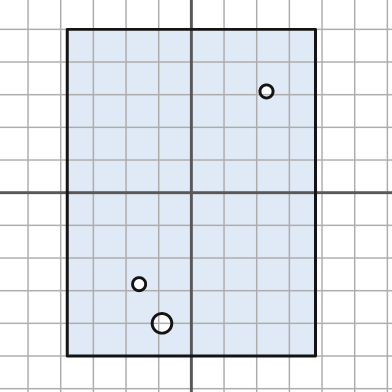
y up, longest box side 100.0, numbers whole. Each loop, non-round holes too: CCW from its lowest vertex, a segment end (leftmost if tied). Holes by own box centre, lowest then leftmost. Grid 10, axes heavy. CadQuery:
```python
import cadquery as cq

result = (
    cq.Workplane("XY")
    .moveTo(-38.0, -50.0)
    .lineTo(38.0, -50.0)
    .lineTo(38.0, 50.0)
    .lineTo(-38.0, 50.0)
    .close()
    .moveTo(-9.0, -40.0)
    .circle(3.0)
    .moveTo(-16.0, -28.0)
    .circle(2.0)
    .moveTo(23.0, 31.0)
    .circle(2.0)
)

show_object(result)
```